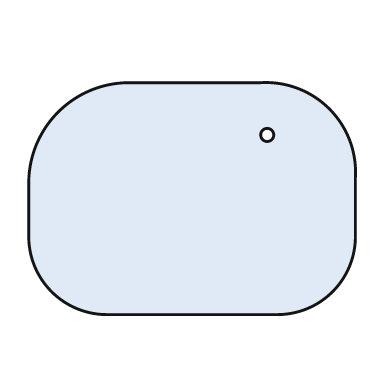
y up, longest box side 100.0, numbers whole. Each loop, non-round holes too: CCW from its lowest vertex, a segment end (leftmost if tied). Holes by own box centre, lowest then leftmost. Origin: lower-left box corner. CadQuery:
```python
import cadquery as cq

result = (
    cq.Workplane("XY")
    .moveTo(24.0, 0.0)
    .lineTo(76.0, 0.0)
    .threePointArc((93.0, 7.0), (100.0, 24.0))
    .lineTo(100.0, 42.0)
    .threePointArc((92.0, 63.0), (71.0, 71.0))
    .lineTo(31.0, 71.0)
    .threePointArc((9.0, 62.0), (0.0, 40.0))
    .lineTo(0.0, 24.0)
    .threePointArc((7.0, 7.0), (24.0, 0.0))
    .close()
    .moveTo(73.0, 55.0)
    .circle(2.0)
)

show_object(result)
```